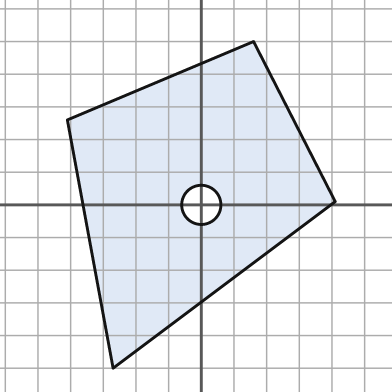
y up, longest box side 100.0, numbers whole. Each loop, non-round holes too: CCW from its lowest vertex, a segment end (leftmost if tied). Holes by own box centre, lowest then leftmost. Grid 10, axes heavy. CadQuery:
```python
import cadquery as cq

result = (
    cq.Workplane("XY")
    .moveTo(-27.0, -50.0)
    .lineTo(41.0, 1.0)
    .lineTo(16.0, 50.0)
    .lineTo(-41.0, 26.0)
    .close()
    .moveTo(0.0, 0.0)
    .circle(6.0)
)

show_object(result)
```